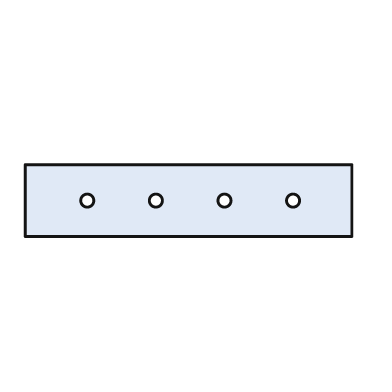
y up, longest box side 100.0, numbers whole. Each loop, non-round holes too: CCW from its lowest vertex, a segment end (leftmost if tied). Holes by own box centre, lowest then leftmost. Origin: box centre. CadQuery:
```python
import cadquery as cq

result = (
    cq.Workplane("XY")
    .moveTo(-50.0, -11.0)
    .lineTo(50.0, -11.0)
    .lineTo(50.0, 11.0)
    .lineTo(-50.0, 11.0)
    .close()
    .moveTo(-31.0, 0.0)
    .circle(2.0)
    .moveTo(-10.0, 0.0)
    .circle(2.0)
    .moveTo(11.0, 0.0)
    .circle(2.0)
    .moveTo(32.0, 0.0)
    .circle(2.0)
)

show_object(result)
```